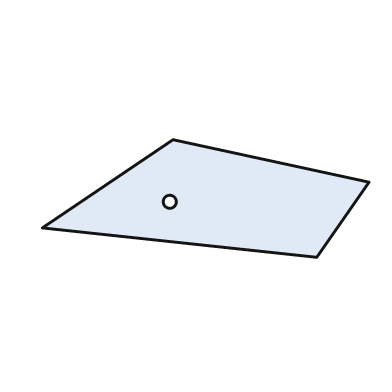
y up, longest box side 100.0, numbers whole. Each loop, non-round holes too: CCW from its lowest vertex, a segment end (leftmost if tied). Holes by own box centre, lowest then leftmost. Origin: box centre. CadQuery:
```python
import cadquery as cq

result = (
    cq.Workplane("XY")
    .moveTo(34.0, -18.0)
    .lineTo(50.0, 5.0)
    .lineTo(-10.0, 18.0)
    .lineTo(-50.0, -9.0)
    .close()
    .moveTo(-11.0, -1.0)
    .circle(2.0)
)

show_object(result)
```